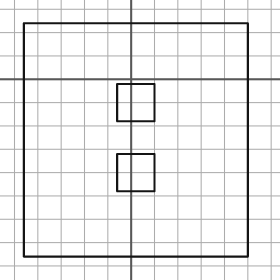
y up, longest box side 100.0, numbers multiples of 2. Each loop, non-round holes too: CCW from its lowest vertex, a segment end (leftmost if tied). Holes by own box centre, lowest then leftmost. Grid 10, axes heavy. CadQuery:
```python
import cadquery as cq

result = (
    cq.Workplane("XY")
    .moveTo(-46.0, -76.0)
    .lineTo(50.0, -76.0)
    .lineTo(50.0, 24.0)
    .lineTo(-46.0, 24.0)
    .close()
    .moveTo(-6.0, -48.0)
    .lineTo(10.0, -48.0)
    .lineTo(10.0, -32.0)
    .lineTo(-6.0, -32.0)
    .close()
    .moveTo(-6.0, -18.0)
    .lineTo(10.0, -18.0)
    .lineTo(10.0, -2.0)
    .lineTo(-6.0, -2.0)
    .close()
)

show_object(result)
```